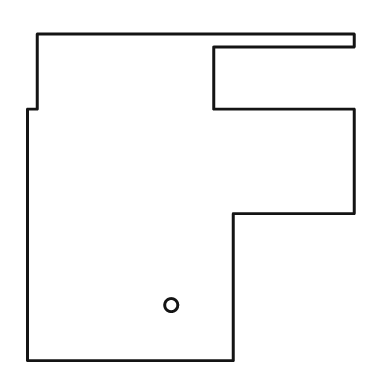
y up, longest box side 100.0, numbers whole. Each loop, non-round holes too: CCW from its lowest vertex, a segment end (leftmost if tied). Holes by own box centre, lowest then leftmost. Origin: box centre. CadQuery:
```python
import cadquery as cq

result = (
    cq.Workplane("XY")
    .moveTo(-50.0, -50.0)
    .lineTo(13.0, -50.0)
    .lineTo(13.0, -5.0)
    .lineTo(50.0, -5.0)
    .lineTo(50.0, 27.0)
    .lineTo(7.0, 27.0)
    .lineTo(7.0, 46.0)
    .lineTo(50.0, 46.0)
    .lineTo(50.0, 50.0)
    .lineTo(-47.0, 50.0)
    .lineTo(-47.0, 27.0)
    .lineTo(-50.0, 27.0)
    .close()
    .moveTo(-6.0, -33.0)
    .circle(2.0)
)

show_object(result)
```